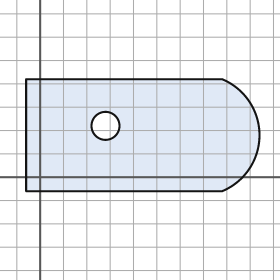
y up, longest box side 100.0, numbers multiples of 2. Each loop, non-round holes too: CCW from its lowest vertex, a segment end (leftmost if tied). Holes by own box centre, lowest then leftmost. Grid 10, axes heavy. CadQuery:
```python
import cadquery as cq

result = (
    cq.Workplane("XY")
    .moveTo(-6.0, -6.0)
    .lineTo(78.0, -6.0)
    .threePointArc((94.0, 18.0), (78.0, 42.0))
    .lineTo(-6.0, 42.0)
    .close()
    .moveTo(28.0, 22.0)
    .circle(6.0)
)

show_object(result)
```